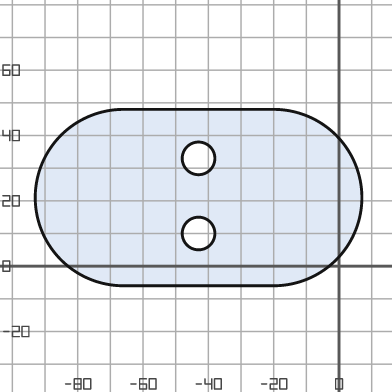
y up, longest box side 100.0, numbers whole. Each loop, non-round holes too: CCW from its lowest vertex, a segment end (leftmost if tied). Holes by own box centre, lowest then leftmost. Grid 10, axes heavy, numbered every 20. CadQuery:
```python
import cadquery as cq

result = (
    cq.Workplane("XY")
    .moveTo(-66.0, -6.0)
    .lineTo(-20.0, -6.0)
    .threePointArc((7.0, 21.0), (-20.0, 48.0))
    .lineTo(-66.0, 48.0)
    .threePointArc((-93.0, 21.0), (-66.0, -6.0))
    .close()
    .moveTo(-43.0, 10.0)
    .circle(5.0)
    .moveTo(-43.0, 33.0)
    .circle(5.0)
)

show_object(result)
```